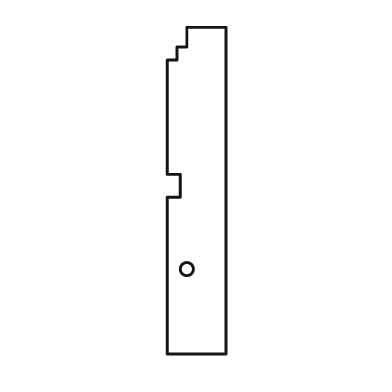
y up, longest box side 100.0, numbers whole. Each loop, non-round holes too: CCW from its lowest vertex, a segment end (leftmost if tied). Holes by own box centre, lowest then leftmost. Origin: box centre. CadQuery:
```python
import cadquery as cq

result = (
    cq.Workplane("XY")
    .moveTo(-9.0, -50.0)
    .lineTo(9.0, -50.0)
    .lineTo(9.0, 50.0)
    .lineTo(-3.0, 50.0)
    .lineTo(-3.0, 44.0)
    .lineTo(-6.0, 44.0)
    .lineTo(-6.0, 40.0)
    .lineTo(-9.0, 40.0)
    .lineTo(-9.0, 5.0)
    .lineTo(-5.0, 5.0)
    .lineTo(-5.0, -2.0)
    .lineTo(-9.0, -2.0)
    .close()
    .moveTo(-3.0, -24.0)
    .circle(2.0)
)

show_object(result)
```